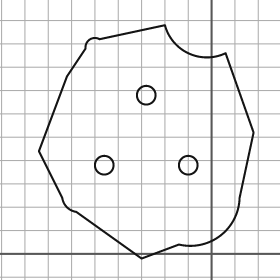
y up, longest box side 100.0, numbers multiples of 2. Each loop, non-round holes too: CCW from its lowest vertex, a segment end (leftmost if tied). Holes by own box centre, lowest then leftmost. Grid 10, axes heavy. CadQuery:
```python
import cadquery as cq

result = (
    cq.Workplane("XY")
    .moveTo(-30.0, -2.0)
    .lineTo(-14.0, 4.0)
    .threePointArc((4.0, 8.0), (12.0, 24.0))
    .lineTo(18.0, 52.0)
    .lineTo(6.0, 86.0)
    .threePointArc((-10.0, 86.0), (-20.0, 98.0))
    .lineTo(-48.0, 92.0)
    .threePointArc((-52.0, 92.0), (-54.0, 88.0))
    .lineTo(-62.0, 76.0)
    .lineTo(-74.0, 44.0)
    .lineTo(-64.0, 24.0)
    .threePointArc((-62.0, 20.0), (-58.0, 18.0))
    .close()
    .moveTo(-46.0, 38.0)
    .circle(4.0)
    .moveTo(-10.0, 38.0)
    .circle(4.0)
    .moveTo(-28.0, 68.0)
    .circle(4.0)
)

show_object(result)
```